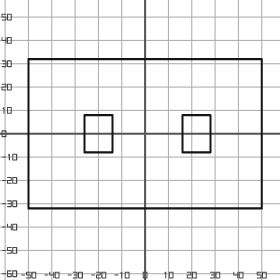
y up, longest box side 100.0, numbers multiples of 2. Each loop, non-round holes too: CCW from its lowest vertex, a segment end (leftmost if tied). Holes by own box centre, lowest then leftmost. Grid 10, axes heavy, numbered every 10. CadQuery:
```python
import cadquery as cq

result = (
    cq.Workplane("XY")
    .moveTo(-50.0, -32.0)
    .lineTo(50.0, -32.0)
    .lineTo(50.0, 32.0)
    .lineTo(-50.0, 32.0)
    .close()
    .moveTo(-26.0, -8.0)
    .lineTo(-14.0, -8.0)
    .lineTo(-14.0, 8.0)
    .lineTo(-26.0, 8.0)
    .close()
    .moveTo(16.0, -8.0)
    .lineTo(28.0, -8.0)
    .lineTo(28.0, 8.0)
    .lineTo(16.0, 8.0)
    .close()
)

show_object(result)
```